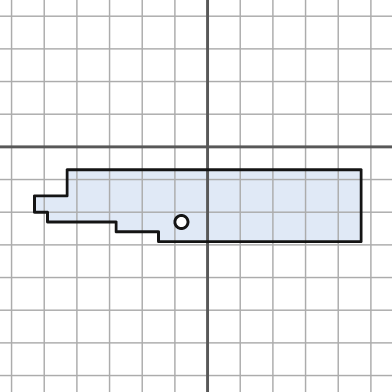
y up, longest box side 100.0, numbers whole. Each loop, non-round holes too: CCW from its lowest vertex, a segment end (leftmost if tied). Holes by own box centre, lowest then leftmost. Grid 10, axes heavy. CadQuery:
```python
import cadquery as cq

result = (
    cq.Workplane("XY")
    .moveTo(-15.0, -29.0)
    .lineTo(47.0, -29.0)
    .lineTo(47.0, -7.0)
    .lineTo(-43.0, -7.0)
    .lineTo(-43.0, -15.0)
    .lineTo(-53.0, -15.0)
    .lineTo(-53.0, -20.0)
    .lineTo(-49.0, -20.0)
    .lineTo(-49.0, -23.0)
    .lineTo(-28.0, -23.0)
    .lineTo(-28.0, -26.0)
    .lineTo(-15.0, -26.0)
    .close()
    .moveTo(-8.0, -23.0)
    .circle(2.0)
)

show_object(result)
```